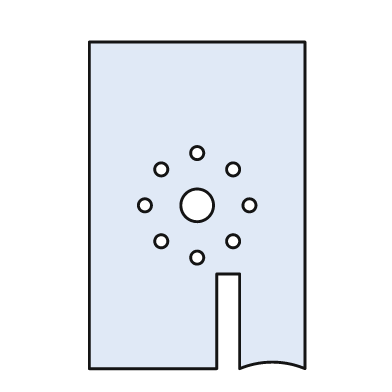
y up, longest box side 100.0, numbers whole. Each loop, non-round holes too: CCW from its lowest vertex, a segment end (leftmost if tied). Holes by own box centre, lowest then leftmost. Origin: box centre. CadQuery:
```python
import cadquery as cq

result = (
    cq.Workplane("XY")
    .moveTo(-33.0, -50.0)
    .lineTo(6.0, -50.0)
    .lineTo(6.0, -21.0)
    .lineTo(13.0, -21.0)
    .lineTo(13.0, -50.0)
    .threePointArc((23.0, -48.0), (33.0, -50.0))
    .lineTo(33.0, 50.0)
    .lineTo(-33.0, 50.0)
    .close()
    .moveTo(0.0, -16.0)
    .circle(2.0)
    .moveTo(-11.0, -11.0)
    .circle(2.0)
    .moveTo(11.0, -11.0)
    .circle(2.0)
    .moveTo(-16.0, 0.0)
    .circle(2.0)
    .moveTo(0.0, 0.0)
    .circle(5.0)
    .moveTo(16.0, 0.0)
    .circle(2.0)
    .moveTo(-11.0, 11.0)
    .circle(2.0)
    .moveTo(11.0, 11.0)
    .circle(2.0)
    .moveTo(0.0, 16.0)
    .circle(2.0)
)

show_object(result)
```